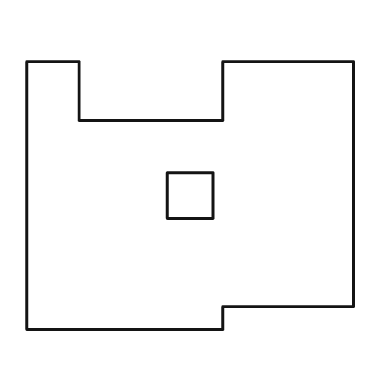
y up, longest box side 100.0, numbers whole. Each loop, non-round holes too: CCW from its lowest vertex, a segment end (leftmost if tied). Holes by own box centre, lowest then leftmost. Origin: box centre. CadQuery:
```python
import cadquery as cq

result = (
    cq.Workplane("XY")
    .moveTo(-50.0, -41.0)
    .lineTo(10.0, -41.0)
    .lineTo(10.0, -34.0)
    .lineTo(50.0, -34.0)
    .lineTo(50.0, 41.0)
    .lineTo(10.0, 41.0)
    .lineTo(10.0, 23.0)
    .lineTo(-34.0, 23.0)
    .lineTo(-34.0, 41.0)
    .lineTo(-50.0, 41.0)
    .close()
    .moveTo(-7.0, -7.0)
    .lineTo(7.0, -7.0)
    .lineTo(7.0, 7.0)
    .lineTo(-7.0, 7.0)
    .close()
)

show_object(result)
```